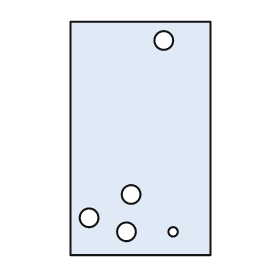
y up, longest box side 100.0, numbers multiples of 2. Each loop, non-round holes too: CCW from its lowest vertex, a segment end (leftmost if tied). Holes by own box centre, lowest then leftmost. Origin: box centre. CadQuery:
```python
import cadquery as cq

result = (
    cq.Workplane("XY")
    .moveTo(-30.0, -50.0)
    .lineTo(30.0, -50.0)
    .lineTo(30.0, 50.0)
    .lineTo(-30.0, 50.0)
    .close()
    .moveTo(-6.0, -40.0)
    .circle(4.0)
    .moveTo(14.0, -40.0)
    .circle(2.0)
    .moveTo(-22.0, -34.0)
    .circle(4.0)
    .moveTo(-4.0, -24.0)
    .circle(4.0)
    .moveTo(10.0, 42.0)
    .circle(4.0)
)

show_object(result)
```